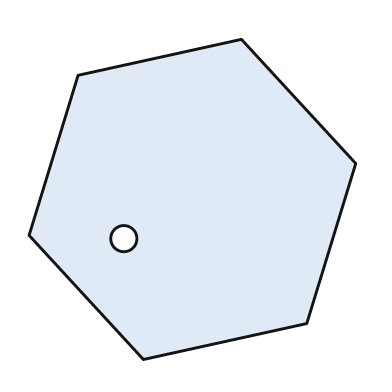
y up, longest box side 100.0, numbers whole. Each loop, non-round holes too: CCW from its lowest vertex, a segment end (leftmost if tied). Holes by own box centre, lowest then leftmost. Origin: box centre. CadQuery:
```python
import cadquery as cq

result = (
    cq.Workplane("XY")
    .moveTo(-15.0, -49.0)
    .lineTo(35.0, -38.0)
    .lineTo(50.0, 11.0)
    .lineTo(15.0, 49.0)
    .lineTo(-35.0, 38.0)
    .lineTo(-50.0, -11.0)
    .close()
    .moveTo(-21.0, -12.0)
    .circle(4.0)
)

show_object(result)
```